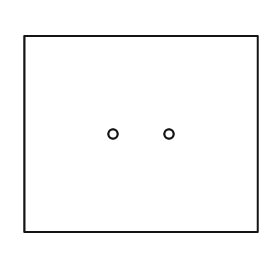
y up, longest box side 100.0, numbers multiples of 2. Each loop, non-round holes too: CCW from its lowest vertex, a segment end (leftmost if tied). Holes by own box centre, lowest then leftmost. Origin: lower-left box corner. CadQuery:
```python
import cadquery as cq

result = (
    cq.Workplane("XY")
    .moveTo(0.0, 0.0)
    .lineTo(100.0, 0.0)
    .lineTo(100.0, 84.0)
    .lineTo(0.0, 84.0)
    .close()
    .moveTo(38.0, 42.0)
    .circle(2.0)
    .moveTo(62.0, 42.0)
    .circle(2.0)
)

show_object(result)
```